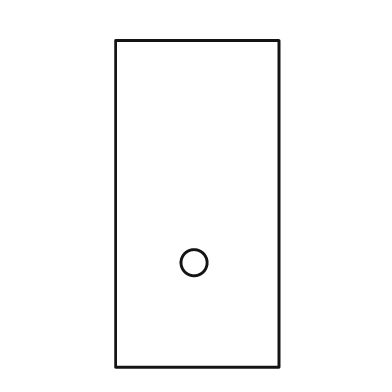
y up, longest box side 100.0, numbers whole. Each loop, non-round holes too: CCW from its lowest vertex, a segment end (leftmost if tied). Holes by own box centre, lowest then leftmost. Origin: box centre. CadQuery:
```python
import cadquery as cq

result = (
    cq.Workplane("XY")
    .moveTo(-25.0, -50.0)
    .lineTo(25.0, -50.0)
    .lineTo(25.0, 50.0)
    .lineTo(-25.0, 50.0)
    .close()
    .moveTo(-1.0, -18.0)
    .circle(4.0)
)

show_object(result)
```